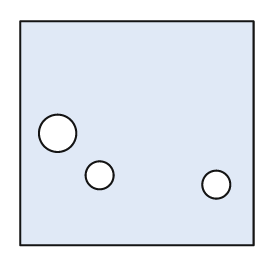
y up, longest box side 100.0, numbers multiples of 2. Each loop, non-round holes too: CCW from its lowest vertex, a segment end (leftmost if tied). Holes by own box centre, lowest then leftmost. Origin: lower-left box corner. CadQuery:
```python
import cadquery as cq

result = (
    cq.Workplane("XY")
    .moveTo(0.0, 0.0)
    .lineTo(100.0, 0.0)
    .lineTo(100.0, 96.0)
    .lineTo(0.0, 96.0)
    .close()
    .moveTo(84.0, 26.0)
    .circle(6.0)
    .moveTo(34.0, 30.0)
    .circle(6.0)
    .moveTo(16.0, 48.0)
    .circle(8.0)
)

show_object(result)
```